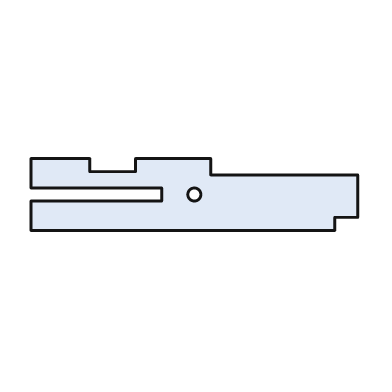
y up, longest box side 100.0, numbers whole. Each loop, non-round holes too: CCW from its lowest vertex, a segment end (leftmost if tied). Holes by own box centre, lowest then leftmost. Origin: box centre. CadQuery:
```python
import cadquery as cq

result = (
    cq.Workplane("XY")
    .moveTo(-50.0, -11.0)
    .lineTo(43.0, -11.0)
    .lineTo(43.0, -7.0)
    .lineTo(50.0, -7.0)
    .lineTo(50.0, 6.0)
    .lineTo(5.0, 6.0)
    .lineTo(5.0, 11.0)
    .lineTo(-18.0, 11.0)
    .lineTo(-18.0, 7.0)
    .lineTo(-32.0, 7.0)
    .lineTo(-32.0, 11.0)
    .lineTo(-50.0, 11.0)
    .lineTo(-50.0, 2.0)
    .lineTo(-10.0, 2.0)
    .lineTo(-10.0, -2.0)
    .lineTo(-50.0, -2.0)
    .close()
    .moveTo(0.0, 0.0)
    .circle(2.0)
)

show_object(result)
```